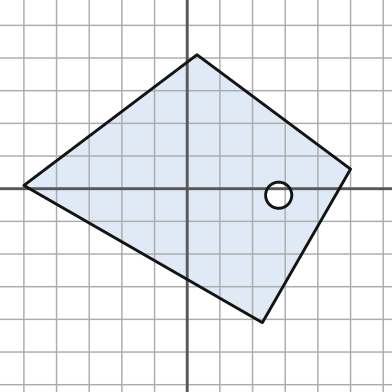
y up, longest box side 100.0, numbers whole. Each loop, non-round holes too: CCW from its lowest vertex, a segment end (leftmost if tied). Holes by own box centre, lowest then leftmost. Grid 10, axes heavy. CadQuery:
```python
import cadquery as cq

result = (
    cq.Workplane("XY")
    .moveTo(23.0, -41.0)
    .lineTo(50.0, 6.0)
    .lineTo(3.0, 41.0)
    .lineTo(-50.0, 1.0)
    .close()
    .moveTo(28.0, -2.0)
    .circle(4.0)
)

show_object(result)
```